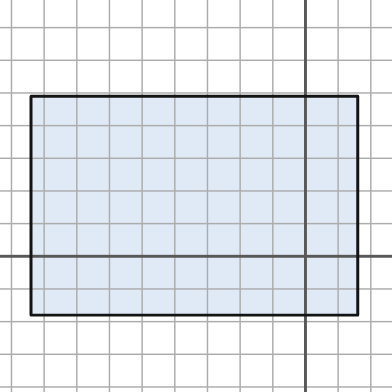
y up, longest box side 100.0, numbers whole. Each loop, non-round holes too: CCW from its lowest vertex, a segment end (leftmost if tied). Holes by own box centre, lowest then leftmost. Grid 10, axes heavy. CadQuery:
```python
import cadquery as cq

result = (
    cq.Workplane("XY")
    .moveTo(-84.0, -18.0)
    .lineTo(16.0, -18.0)
    .lineTo(16.0, 49.0)
    .lineTo(-84.0, 49.0)
    .close()
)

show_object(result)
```